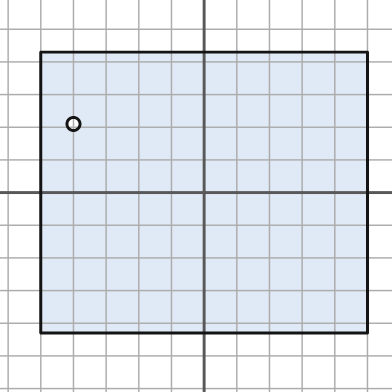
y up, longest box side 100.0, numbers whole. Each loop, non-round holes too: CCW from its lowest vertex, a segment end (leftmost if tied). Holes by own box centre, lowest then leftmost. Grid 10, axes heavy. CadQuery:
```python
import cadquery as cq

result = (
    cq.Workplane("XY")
    .moveTo(-50.0, -43.0)
    .lineTo(50.0, -43.0)
    .lineTo(50.0, 43.0)
    .lineTo(-50.0, 43.0)
    .close()
    .moveTo(-40.0, 21.0)
    .circle(2.0)
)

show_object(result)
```